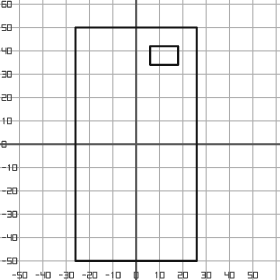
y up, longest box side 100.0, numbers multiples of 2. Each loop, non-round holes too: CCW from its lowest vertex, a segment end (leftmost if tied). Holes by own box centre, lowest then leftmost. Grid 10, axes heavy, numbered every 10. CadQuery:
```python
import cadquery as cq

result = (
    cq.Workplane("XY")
    .moveTo(-26.0, -50.0)
    .lineTo(26.0, -50.0)
    .lineTo(26.0, 50.0)
    .lineTo(-26.0, 50.0)
    .close()
    .moveTo(6.0, 34.0)
    .lineTo(18.0, 34.0)
    .lineTo(18.0, 42.0)
    .lineTo(6.0, 42.0)
    .close()
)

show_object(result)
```